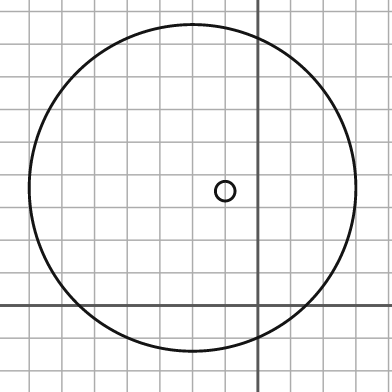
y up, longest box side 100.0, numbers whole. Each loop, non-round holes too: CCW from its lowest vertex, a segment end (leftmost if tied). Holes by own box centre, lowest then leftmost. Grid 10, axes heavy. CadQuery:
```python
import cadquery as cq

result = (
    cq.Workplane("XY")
    .moveTo(-20.0, 36.0)
    .circle(50.0)
    .moveTo(-10.0, 35.0)
    .circle(3.0)
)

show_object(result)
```